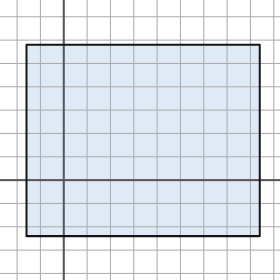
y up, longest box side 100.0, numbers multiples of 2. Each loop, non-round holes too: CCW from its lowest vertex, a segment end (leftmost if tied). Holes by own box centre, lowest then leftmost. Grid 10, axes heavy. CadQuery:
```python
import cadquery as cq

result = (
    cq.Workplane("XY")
    .moveTo(-16.0, -24.0)
    .lineTo(84.0, -24.0)
    .lineTo(84.0, 58.0)
    .lineTo(-16.0, 58.0)
    .close()
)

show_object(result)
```